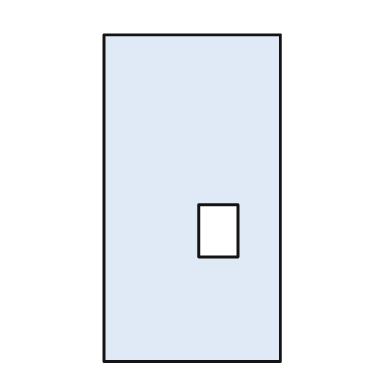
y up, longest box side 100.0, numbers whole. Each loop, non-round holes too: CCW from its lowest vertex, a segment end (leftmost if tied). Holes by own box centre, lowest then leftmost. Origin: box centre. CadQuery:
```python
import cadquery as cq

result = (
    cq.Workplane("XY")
    .moveTo(-27.0, -50.0)
    .lineTo(27.0, -50.0)
    .lineTo(27.0, 50.0)
    .lineTo(-27.0, 50.0)
    .close()
    .moveTo(2.0, -18.0)
    .lineTo(14.0, -18.0)
    .lineTo(14.0, -2.0)
    .lineTo(2.0, -2.0)
    .close()
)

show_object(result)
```